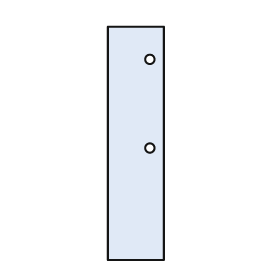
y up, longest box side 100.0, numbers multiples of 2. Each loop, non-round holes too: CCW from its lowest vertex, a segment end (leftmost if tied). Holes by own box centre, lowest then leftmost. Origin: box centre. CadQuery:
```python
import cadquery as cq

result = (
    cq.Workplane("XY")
    .moveTo(-12.0, -50.0)
    .lineTo(12.0, -50.0)
    .lineTo(12.0, 50.0)
    .lineTo(-12.0, 50.0)
    .close()
    .moveTo(6.0, -2.0)
    .circle(2.0)
    .moveTo(6.0, 36.0)
    .circle(2.0)
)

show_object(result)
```